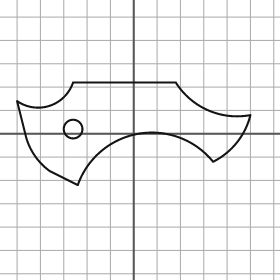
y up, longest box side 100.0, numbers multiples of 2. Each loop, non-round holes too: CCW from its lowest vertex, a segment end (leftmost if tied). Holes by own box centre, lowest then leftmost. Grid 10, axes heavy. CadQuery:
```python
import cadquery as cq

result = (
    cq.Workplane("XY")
    .moveTo(-24.0, -22.0)
    .threePointArc((2.0, 0.0), (34.0, -12.0))
    .threePointArc((44.0, -4.0), (50.0, 8.0))
    .threePointArc((32.0, 10.0), (18.0, 22.0))
    .lineTo(-26.0, 22.0)
    .threePointArc((-36.0, 12.0), (-50.0, 14.0))
    .lineTo(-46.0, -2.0)
    .threePointArc((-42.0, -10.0), (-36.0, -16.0))
    .close()
    .moveTo(-26.0, 2.0)
    .circle(4.0)
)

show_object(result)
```